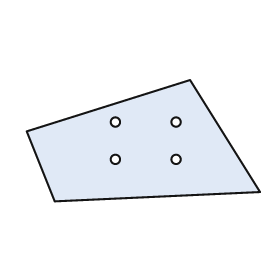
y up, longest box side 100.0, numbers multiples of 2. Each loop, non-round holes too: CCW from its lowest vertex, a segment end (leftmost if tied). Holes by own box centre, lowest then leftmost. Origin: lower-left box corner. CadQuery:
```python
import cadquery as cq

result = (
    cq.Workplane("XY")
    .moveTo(12.0, 0.0)
    .lineTo(100.0, 4.0)
    .lineTo(70.0, 52.0)
    .lineTo(0.0, 30.0)
    .close()
    .moveTo(38.0, 18.0)
    .circle(2.0)
    .moveTo(64.0, 18.0)
    .circle(2.0)
    .moveTo(38.0, 34.0)
    .circle(2.0)
    .moveTo(64.0, 34.0)
    .circle(2.0)
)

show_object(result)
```